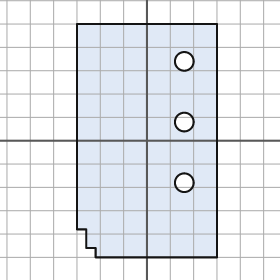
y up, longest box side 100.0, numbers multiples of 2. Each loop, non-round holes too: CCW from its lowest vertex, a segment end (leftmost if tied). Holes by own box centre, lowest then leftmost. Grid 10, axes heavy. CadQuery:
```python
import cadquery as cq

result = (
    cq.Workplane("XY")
    .moveTo(-22.0, -50.0)
    .lineTo(30.0, -50.0)
    .lineTo(30.0, 50.0)
    .lineTo(-30.0, 50.0)
    .lineTo(-30.0, -38.0)
    .lineTo(-26.0, -38.0)
    .lineTo(-26.0, -46.0)
    .lineTo(-22.0, -46.0)
    .close()
    .moveTo(16.0, -18.0)
    .circle(4.0)
    .moveTo(16.0, 8.0)
    .circle(4.0)
    .moveTo(16.0, 34.0)
    .circle(4.0)
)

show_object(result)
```